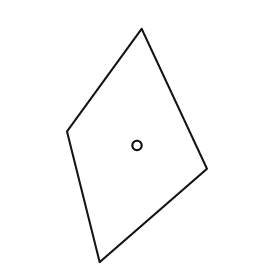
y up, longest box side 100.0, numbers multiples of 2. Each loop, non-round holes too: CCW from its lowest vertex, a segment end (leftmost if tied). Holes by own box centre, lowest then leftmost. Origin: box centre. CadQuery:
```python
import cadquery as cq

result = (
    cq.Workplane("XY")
    .moveTo(-16.0, -50.0)
    .lineTo(30.0, -10.0)
    .lineTo(2.0, 50.0)
    .lineTo(-30.0, 6.0)
    .close()
    .moveTo(0.0, 0.0)
    .circle(2.0)
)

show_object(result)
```